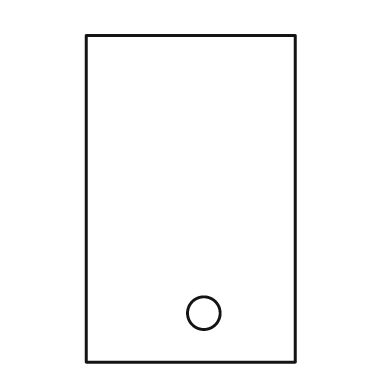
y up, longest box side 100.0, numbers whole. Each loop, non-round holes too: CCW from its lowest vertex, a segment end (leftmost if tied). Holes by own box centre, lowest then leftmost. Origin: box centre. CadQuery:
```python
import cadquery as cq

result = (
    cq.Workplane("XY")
    .moveTo(-32.0, -50.0)
    .lineTo(32.0, -50.0)
    .lineTo(32.0, 50.0)
    .lineTo(-32.0, 50.0)
    .close()
    .moveTo(4.0, -35.0)
    .circle(5.0)
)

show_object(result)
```